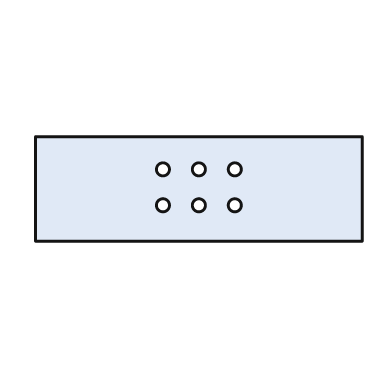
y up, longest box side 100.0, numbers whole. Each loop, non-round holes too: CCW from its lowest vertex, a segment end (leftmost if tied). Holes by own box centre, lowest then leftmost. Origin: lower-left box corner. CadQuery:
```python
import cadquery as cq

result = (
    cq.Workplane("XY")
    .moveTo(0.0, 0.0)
    .lineTo(100.0, 0.0)
    .lineTo(100.0, 32.0)
    .lineTo(0.0, 32.0)
    .close()
    .moveTo(39.0, 11.0)
    .circle(2.0)
    .moveTo(50.0, 11.0)
    .circle(2.0)
    .moveTo(61.0, 11.0)
    .circle(2.0)
    .moveTo(39.0, 22.0)
    .circle(2.0)
    .moveTo(50.0, 22.0)
    .circle(2.0)
    .moveTo(61.0, 22.0)
    .circle(2.0)
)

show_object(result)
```